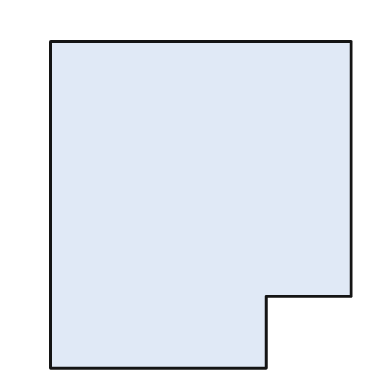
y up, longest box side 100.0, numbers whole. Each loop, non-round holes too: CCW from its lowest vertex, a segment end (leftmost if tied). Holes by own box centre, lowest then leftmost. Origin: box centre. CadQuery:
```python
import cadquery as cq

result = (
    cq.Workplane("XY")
    .moveTo(-46.0, -50.0)
    .lineTo(20.0, -50.0)
    .lineTo(20.0, -28.0)
    .lineTo(46.0, -28.0)
    .lineTo(46.0, 50.0)
    .lineTo(-46.0, 50.0)
    .close()
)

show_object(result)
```